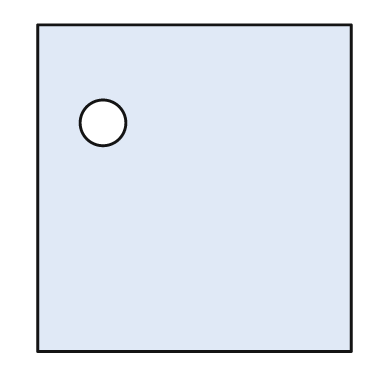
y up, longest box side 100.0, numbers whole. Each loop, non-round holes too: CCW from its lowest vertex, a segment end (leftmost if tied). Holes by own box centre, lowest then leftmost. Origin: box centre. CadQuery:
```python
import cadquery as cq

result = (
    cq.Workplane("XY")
    .moveTo(-48.0, -50.0)
    .lineTo(48.0, -50.0)
    .lineTo(48.0, 50.0)
    .lineTo(-48.0, 50.0)
    .close()
    .moveTo(-28.0, 20.0)
    .circle(7.0)
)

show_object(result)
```